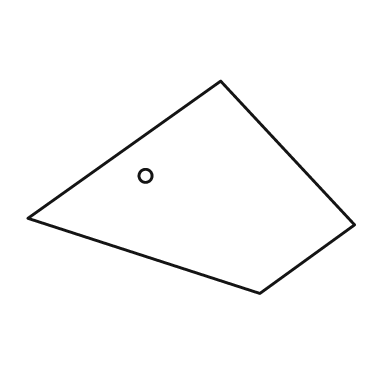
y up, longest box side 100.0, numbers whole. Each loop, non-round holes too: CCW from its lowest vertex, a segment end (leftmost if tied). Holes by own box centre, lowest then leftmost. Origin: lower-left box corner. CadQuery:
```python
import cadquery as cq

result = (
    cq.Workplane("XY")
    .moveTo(71.0, 0.0)
    .lineTo(100.0, 21.0)
    .lineTo(59.0, 65.0)
    .lineTo(0.0, 23.0)
    .close()
    .moveTo(36.0, 36.0)
    .circle(2.0)
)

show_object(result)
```